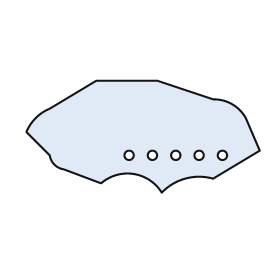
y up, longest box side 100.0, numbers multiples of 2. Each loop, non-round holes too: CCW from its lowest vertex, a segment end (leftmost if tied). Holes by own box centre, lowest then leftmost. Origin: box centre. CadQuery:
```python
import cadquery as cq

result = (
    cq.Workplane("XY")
    .moveTo(8.0, -24.0)
    .threePointArc((18.0, -18.0), (30.0, -18.0))
    .lineTo(50.0, -6.0)
    .lineTo(44.0, 8.0)
    .threePointArc((38.0, 14.0), (30.0, 16.0))
    .lineTo(6.0, 24.0)
    .lineTo(-20.0, 24.0)
    .lineTo(-40.0, 12.0)
    .threePointArc((-46.0, 8.0), (-50.0, 2.0))
    .lineTo(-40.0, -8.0)
    .threePointArc((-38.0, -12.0), (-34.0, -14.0))
    .lineTo(-18.0, -20.0)
    .threePointArc((-4.0, -16.0), (8.0, -24.0))
    .close()
    .moveTo(-6.0, -8.0)
    .circle(2.0)
    .moveTo(4.0, -8.0)
    .circle(2.0)
    .moveTo(14.0, -8.0)
    .circle(2.0)
    .moveTo(24.0, -8.0)
    .circle(2.0)
    .moveTo(34.0, -8.0)
    .circle(2.0)
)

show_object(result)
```